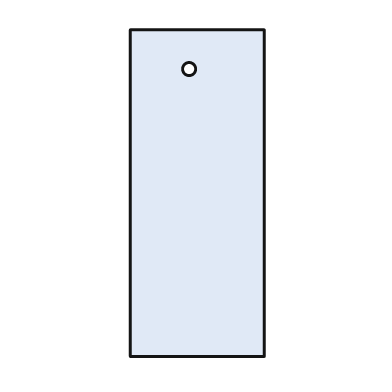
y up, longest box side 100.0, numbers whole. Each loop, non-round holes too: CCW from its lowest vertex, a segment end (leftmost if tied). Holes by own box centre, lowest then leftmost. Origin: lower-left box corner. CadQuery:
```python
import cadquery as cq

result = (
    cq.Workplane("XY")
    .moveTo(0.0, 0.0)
    .lineTo(41.0, 0.0)
    .lineTo(41.0, 100.0)
    .lineTo(0.0, 100.0)
    .close()
    .moveTo(18.0, 88.0)
    .circle(2.0)
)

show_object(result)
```